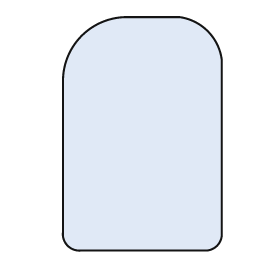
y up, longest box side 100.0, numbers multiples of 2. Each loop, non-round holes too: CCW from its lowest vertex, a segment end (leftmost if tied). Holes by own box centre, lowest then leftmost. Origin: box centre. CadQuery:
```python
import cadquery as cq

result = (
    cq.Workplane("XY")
    .moveTo(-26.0, -50.0)
    .lineTo(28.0, -50.0)
    .threePointArc((32.0, -48.0), (34.0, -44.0))
    .lineTo(34.0, 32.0)
    .threePointArc((28.0, 44.0), (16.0, 50.0))
    .lineTo(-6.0, 50.0)
    .threePointArc((-26.0, 42.0), (-34.0, 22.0))
    .lineTo(-34.0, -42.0)
    .threePointArc((-32.0, -48.0), (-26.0, -50.0))
    .close()
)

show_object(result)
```